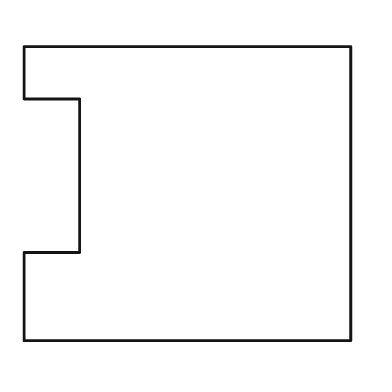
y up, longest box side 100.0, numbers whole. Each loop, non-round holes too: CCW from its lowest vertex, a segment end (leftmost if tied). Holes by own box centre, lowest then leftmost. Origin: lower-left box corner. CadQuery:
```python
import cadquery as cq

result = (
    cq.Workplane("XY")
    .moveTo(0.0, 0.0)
    .lineTo(100.0, 0.0)
    .lineTo(100.0, 90.0)
    .lineTo(0.0, 90.0)
    .lineTo(0.0, 74.0)
    .lineTo(17.0, 74.0)
    .lineTo(17.0, 27.0)
    .lineTo(0.0, 27.0)
    .close()
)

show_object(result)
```